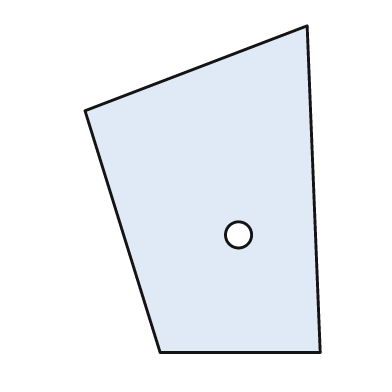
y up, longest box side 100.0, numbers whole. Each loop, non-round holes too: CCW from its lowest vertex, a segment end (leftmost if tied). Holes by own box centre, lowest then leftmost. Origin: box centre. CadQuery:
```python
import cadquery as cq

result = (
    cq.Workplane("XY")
    .moveTo(-13.0, -50.0)
    .lineTo(36.0, -50.0)
    .lineTo(32.0, 50.0)
    .lineTo(-36.0, 24.0)
    .close()
    .moveTo(11.0, -14.0)
    .circle(4.0)
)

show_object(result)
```